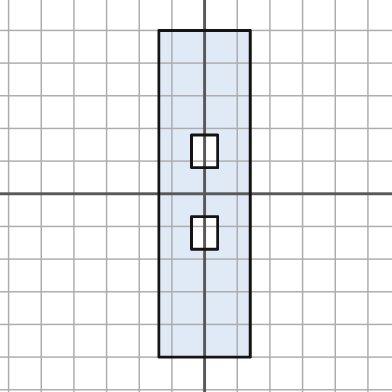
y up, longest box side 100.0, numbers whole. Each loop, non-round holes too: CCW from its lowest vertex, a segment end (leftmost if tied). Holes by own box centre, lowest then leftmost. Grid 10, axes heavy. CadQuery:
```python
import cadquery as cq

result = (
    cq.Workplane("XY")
    .moveTo(-14.0, -50.0)
    .lineTo(14.0, -50.0)
    .lineTo(14.0, 50.0)
    .lineTo(-14.0, 50.0)
    .close()
    .moveTo(-4.0, -17.0)
    .lineTo(4.0, -17.0)
    .lineTo(4.0, -7.0)
    .lineTo(-4.0, -7.0)
    .close()
    .moveTo(-4.0, 8.0)
    .lineTo(4.0, 8.0)
    .lineTo(4.0, 18.0)
    .lineTo(-4.0, 18.0)
    .close()
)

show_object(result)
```